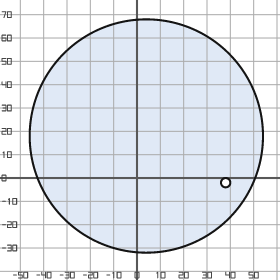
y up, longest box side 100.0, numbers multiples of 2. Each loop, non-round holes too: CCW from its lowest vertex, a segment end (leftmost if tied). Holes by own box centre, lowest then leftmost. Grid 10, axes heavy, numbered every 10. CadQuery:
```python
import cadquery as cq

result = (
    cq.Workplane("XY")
    .moveTo(4.0, 18.0)
    .circle(50.0)
    .moveTo(38.0, -2.0)
    .circle(2.0)
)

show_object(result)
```